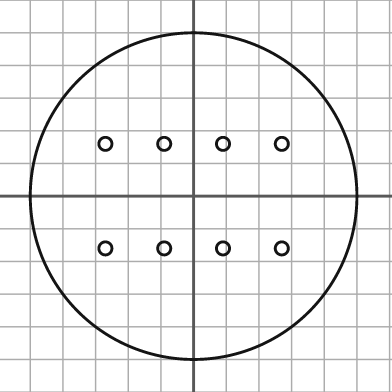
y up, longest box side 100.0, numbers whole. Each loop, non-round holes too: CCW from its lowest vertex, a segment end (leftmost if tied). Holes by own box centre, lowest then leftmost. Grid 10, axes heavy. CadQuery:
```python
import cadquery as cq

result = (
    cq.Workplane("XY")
    .moveTo(0.0, 0.0)
    .circle(50.0)
    .moveTo(-27.0, -16.0)
    .circle(2.0)
    .moveTo(-9.0, -16.0)
    .circle(2.0)
    .moveTo(9.0, -16.0)
    .circle(2.0)
    .moveTo(27.0, -16.0)
    .circle(2.0)
    .moveTo(-27.0, 16.0)
    .circle(2.0)
    .moveTo(-9.0, 16.0)
    .circle(2.0)
    .moveTo(9.0, 16.0)
    .circle(2.0)
    .moveTo(27.0, 16.0)
    .circle(2.0)
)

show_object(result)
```